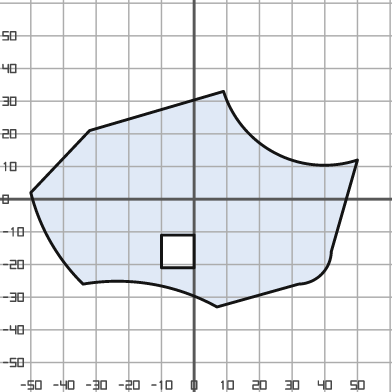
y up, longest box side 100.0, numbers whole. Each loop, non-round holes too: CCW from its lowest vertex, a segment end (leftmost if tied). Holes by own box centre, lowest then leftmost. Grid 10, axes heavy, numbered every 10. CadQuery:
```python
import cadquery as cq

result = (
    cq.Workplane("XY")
    .moveTo(7.0, -33.0)
    .lineTo(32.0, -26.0)
    .threePointArc((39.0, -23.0), (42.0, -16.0))
    .lineTo(50.0, 12.0)
    .threePointArc((25.0, 14.0), (9.0, 33.0))
    .lineTo(-32.0, 21.0)
    .lineTo(-50.0, 2.0)
    .threePointArc((-44.0, -13.0), (-34.0, -26.0))
    .threePointArc((-13.0, -26.0), (7.0, -33.0))
    .close()
    .moveTo(-10.0, -21.0)
    .lineTo(0.0, -21.0)
    .lineTo(0.0, -11.0)
    .lineTo(-10.0, -11.0)
    .close()
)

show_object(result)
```